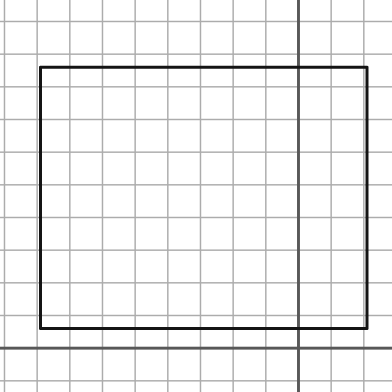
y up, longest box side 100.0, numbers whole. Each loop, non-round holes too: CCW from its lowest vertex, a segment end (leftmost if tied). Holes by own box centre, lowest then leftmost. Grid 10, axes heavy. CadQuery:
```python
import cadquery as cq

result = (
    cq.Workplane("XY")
    .moveTo(-79.0, 6.0)
    .lineTo(21.0, 6.0)
    .lineTo(21.0, 86.0)
    .lineTo(-79.0, 86.0)
    .close()
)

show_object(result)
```